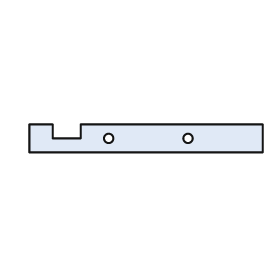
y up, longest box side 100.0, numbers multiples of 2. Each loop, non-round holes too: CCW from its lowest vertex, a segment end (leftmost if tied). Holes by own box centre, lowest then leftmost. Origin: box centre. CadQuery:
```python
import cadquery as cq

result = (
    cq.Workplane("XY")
    .moveTo(-50.0, -6.0)
    .lineTo(50.0, -6.0)
    .lineTo(50.0, 6.0)
    .lineTo(-28.0, 6.0)
    .lineTo(-28.0, 0.0)
    .lineTo(-40.0, 0.0)
    .lineTo(-40.0, 6.0)
    .lineTo(-50.0, 6.0)
    .close()
    .moveTo(-16.0, 0.0)
    .circle(2.0)
    .moveTo(18.0, 0.0)
    .circle(2.0)
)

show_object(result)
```